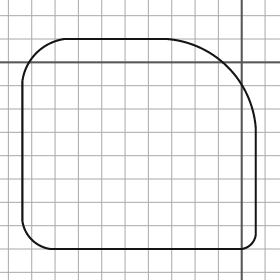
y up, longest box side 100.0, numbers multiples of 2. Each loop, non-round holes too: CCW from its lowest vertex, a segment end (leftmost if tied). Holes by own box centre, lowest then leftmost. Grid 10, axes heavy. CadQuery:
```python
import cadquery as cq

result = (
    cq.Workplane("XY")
    .moveTo(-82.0, -80.0)
    .lineTo(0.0, -80.0)
    .threePointArc((4.0, -78.0), (6.0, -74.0))
    .lineTo(6.0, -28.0)
    .threePointArc((-6.0, -2.0), (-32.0, 10.0))
    .lineTo(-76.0, 10.0)
    .threePointArc((-88.0, 4.0), (-94.0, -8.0))
    .lineTo(-94.0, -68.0)
    .threePointArc((-90.0, -76.0), (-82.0, -80.0))
    .close()
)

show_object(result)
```